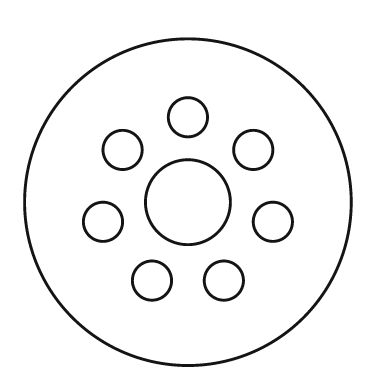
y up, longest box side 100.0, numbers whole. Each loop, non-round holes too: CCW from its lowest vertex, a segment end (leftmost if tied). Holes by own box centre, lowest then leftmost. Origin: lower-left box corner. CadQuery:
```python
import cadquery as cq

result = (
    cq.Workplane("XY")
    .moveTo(50.0, 50.0)
    .circle(50.0)
    .moveTo(39.0, 26.0)
    .circle(6.0)
    .moveTo(61.0, 26.0)
    .circle(6.0)
    .moveTo(24.0, 44.0)
    .circle(6.0)
    .moveTo(76.0, 44.0)
    .circle(6.0)
    .moveTo(50.0, 50.0)
    .circle(13.0)
    .moveTo(30.0, 66.0)
    .circle(6.0)
    .moveTo(70.0, 66.0)
    .circle(6.0)
    .moveTo(50.0, 76.0)
    .circle(6.0)
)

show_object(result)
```